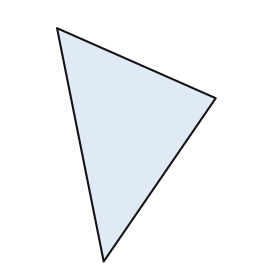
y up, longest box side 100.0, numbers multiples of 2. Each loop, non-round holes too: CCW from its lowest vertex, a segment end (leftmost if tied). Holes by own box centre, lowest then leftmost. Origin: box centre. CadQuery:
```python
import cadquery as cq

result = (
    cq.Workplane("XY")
    .moveTo(-14.0, -50.0)
    .lineTo(34.0, 20.0)
    .lineTo(-34.0, 50.0)
    .close()
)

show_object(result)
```